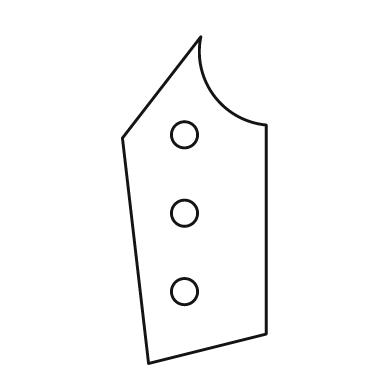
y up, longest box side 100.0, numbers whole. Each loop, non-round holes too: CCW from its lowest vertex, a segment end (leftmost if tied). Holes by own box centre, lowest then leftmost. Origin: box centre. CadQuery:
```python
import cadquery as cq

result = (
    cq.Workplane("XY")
    .moveTo(-14.0, -50.0)
    .lineTo(22.0, -41.0)
    .lineTo(22.0, 23.0)
    .threePointArc((6.0, 32.0), (2.0, 50.0))
    .lineTo(-22.0, 19.0)
    .close()
    .moveTo(-3.0, -28.0)
    .circle(4.0)
    .moveTo(-3.0, -4.0)
    .circle(4.0)
    .moveTo(-3.0, 20.0)
    .circle(4.0)
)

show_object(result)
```